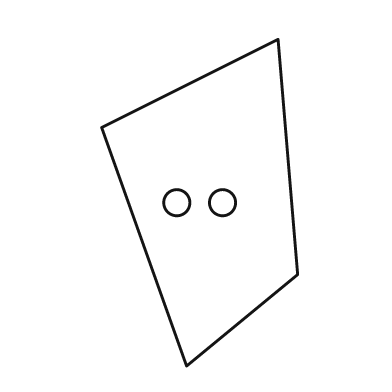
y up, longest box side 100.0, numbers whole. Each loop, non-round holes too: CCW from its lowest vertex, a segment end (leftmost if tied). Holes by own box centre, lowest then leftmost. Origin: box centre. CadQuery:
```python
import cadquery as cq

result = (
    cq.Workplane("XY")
    .moveTo(-4.0, -50.0)
    .lineTo(30.0, -22.0)
    .lineTo(24.0, 50.0)
    .lineTo(-30.0, 23.0)
    .close()
    .moveTo(-7.0, 0.0)
    .circle(4.0)
    .moveTo(7.0, 0.0)
    .circle(4.0)
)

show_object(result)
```